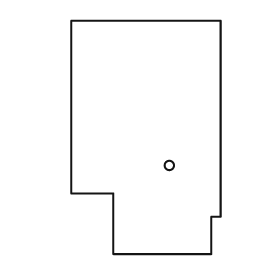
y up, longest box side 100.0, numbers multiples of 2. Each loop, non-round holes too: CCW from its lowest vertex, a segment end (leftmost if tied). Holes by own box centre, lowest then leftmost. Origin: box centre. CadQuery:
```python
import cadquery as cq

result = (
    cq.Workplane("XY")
    .moveTo(-14.0, -50.0)
    .lineTo(28.0, -50.0)
    .lineTo(28.0, -34.0)
    .lineTo(32.0, -34.0)
    .lineTo(32.0, 50.0)
    .lineTo(-32.0, 50.0)
    .lineTo(-32.0, -24.0)
    .lineTo(-14.0, -24.0)
    .close()
    .moveTo(10.0, -12.0)
    .circle(2.0)
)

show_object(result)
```